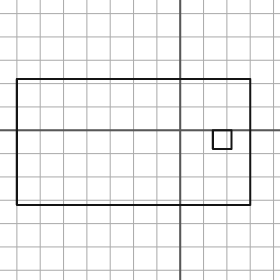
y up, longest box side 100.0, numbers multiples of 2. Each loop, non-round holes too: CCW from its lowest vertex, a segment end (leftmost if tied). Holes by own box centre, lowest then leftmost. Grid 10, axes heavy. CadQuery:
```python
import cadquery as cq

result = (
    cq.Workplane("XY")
    .moveTo(-70.0, -32.0)
    .lineTo(30.0, -32.0)
    .lineTo(30.0, 22.0)
    .lineTo(-70.0, 22.0)
    .close()
    .moveTo(14.0, -8.0)
    .lineTo(22.0, -8.0)
    .lineTo(22.0, 0.0)
    .lineTo(14.0, 0.0)
    .close()
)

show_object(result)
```